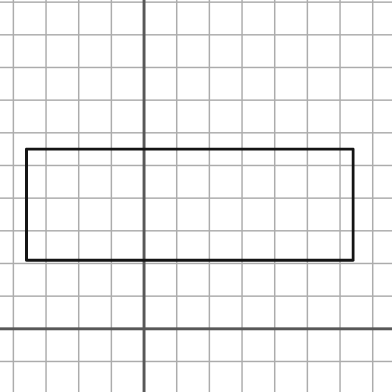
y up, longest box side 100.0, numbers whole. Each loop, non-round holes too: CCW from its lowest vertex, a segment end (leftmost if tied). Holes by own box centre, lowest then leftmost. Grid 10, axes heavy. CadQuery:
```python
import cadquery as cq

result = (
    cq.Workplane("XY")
    .moveTo(-36.0, 21.0)
    .lineTo(64.0, 21.0)
    .lineTo(64.0, 55.0)
    .lineTo(-36.0, 55.0)
    .close()
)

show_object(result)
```